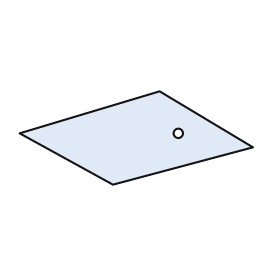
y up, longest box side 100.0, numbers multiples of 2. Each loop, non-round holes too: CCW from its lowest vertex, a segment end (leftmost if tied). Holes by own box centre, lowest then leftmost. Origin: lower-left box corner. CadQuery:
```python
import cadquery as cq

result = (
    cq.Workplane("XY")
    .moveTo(40.0, 0.0)
    .lineTo(100.0, 16.0)
    .lineTo(60.0, 40.0)
    .lineTo(0.0, 22.0)
    .close()
    .moveTo(68.0, 22.0)
    .circle(2.0)
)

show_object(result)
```